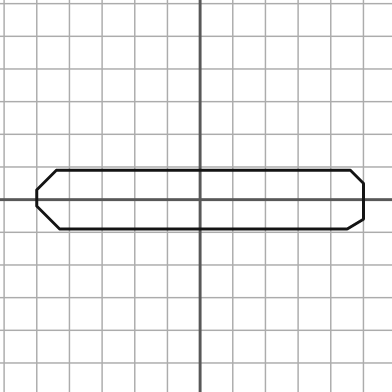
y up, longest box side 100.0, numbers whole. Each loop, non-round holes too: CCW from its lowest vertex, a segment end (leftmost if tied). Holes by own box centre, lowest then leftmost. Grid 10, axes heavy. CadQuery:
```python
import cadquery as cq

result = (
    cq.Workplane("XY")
    .moveTo(-43.0, -9.0)
    .lineTo(45.0, -9.0)
    .lineTo(50.0, -6.0)
    .lineTo(50.0, 5.0)
    .lineTo(46.0, 9.0)
    .lineTo(-44.0, 9.0)
    .lineTo(-50.0, 3.0)
    .lineTo(-50.0, -2.0)
    .close()
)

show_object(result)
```